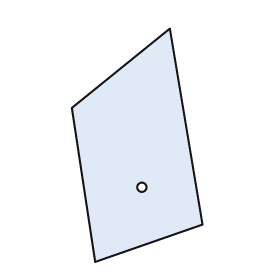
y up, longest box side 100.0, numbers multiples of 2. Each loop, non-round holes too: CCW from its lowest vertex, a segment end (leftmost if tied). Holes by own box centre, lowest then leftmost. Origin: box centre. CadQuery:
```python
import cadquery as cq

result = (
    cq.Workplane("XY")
    .moveTo(-18.0, -50.0)
    .lineTo(28.0, -34.0)
    .lineTo(14.0, 50.0)
    .lineTo(-28.0, 16.0)
    .close()
    .moveTo(2.0, -18.0)
    .circle(2.0)
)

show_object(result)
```